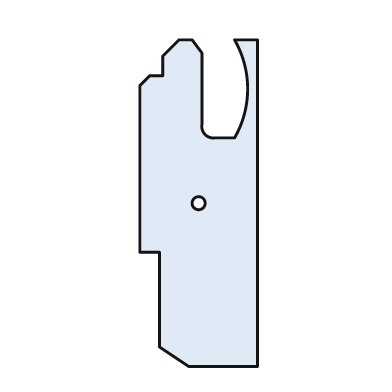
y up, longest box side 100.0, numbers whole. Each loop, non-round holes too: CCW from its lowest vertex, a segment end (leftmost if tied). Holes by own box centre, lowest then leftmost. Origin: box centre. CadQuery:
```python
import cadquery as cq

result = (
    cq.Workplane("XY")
    .moveTo(-3.0, -50.0)
    .lineTo(18.0, -50.0)
    .lineTo(18.0, 50.0)
    .lineTo(11.0, 50.0)
    .threePointArc((15.0, 35.0), (11.0, 20.0))
    .lineTo(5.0, 20.0)
    .threePointArc((2.0, 21.0), (1.0, 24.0))
    .lineTo(1.0, 46.0)
    .lineTo(-2.0, 50.0)
    .lineTo(-6.0, 50.0)
    .lineTo(-11.0, 45.0)
    .lineTo(-11.0, 39.0)
    .lineTo(-15.0, 39.0)
    .lineTo(-18.0, 36.0)
    .lineTo(-18.0, -15.0)
    .lineTo(-12.0, -15.0)
    .lineTo(-12.0, -44.0)
    .close()
    .moveTo(0.0, 0.0)
    .circle(2.0)
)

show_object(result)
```